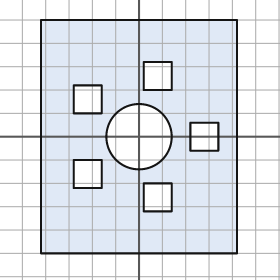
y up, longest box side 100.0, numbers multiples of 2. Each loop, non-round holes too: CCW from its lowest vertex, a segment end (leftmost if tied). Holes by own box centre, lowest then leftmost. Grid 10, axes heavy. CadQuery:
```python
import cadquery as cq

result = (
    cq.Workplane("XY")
    .moveTo(-42.0, -50.0)
    .lineTo(42.0, -50.0)
    .lineTo(42.0, 50.0)
    .lineTo(-42.0, 50.0)
    .close()
    .moveTo(2.0, -32.0)
    .lineTo(14.0, -32.0)
    .lineTo(14.0, -20.0)
    .lineTo(2.0, -20.0)
    .close()
    .moveTo(-28.0, -22.0)
    .lineTo(-16.0, -22.0)
    .lineTo(-16.0, -10.0)
    .lineTo(-28.0, -10.0)
    .close()
    .moveTo(0.0, 0.0)
    .circle(14.0)
    .moveTo(22.0, -6.0)
    .lineTo(34.0, -6.0)
    .lineTo(34.0, 6.0)
    .lineTo(22.0, 6.0)
    .close()
    .moveTo(-28.0, 10.0)
    .lineTo(-16.0, 10.0)
    .lineTo(-16.0, 22.0)
    .lineTo(-28.0, 22.0)
    .close()
    .moveTo(2.0, 20.0)
    .lineTo(14.0, 20.0)
    .lineTo(14.0, 32.0)
    .lineTo(2.0, 32.0)
    .close()
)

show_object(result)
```